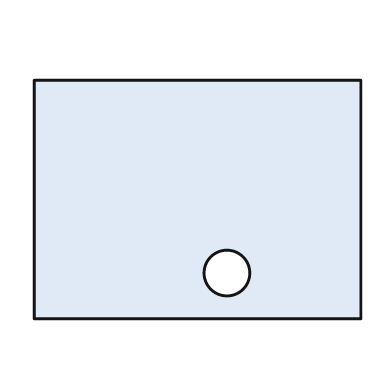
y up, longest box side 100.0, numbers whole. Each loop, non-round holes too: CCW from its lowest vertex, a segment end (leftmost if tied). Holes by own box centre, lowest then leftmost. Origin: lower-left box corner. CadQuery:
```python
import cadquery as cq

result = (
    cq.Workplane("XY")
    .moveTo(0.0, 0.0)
    .lineTo(100.0, 0.0)
    .lineTo(100.0, 73.0)
    .lineTo(0.0, 73.0)
    .close()
    .moveTo(59.0, 14.0)
    .circle(7.0)
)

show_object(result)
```